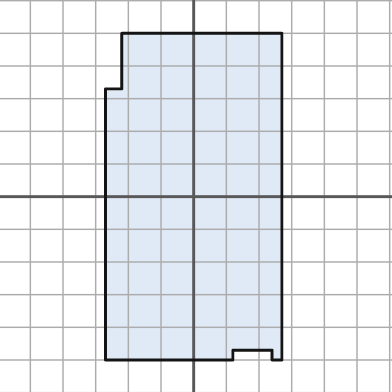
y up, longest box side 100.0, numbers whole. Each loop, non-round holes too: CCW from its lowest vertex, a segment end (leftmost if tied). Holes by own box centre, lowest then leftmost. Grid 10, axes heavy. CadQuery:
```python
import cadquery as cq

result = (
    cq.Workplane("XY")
    .moveTo(-27.0, -50.0)
    .lineTo(12.0, -50.0)
    .lineTo(12.0, -47.0)
    .lineTo(24.0, -47.0)
    .lineTo(24.0, -50.0)
    .lineTo(27.0, -50.0)
    .lineTo(27.0, 50.0)
    .lineTo(-22.0, 50.0)
    .lineTo(-22.0, 33.0)
    .lineTo(-27.0, 33.0)
    .close()
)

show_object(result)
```